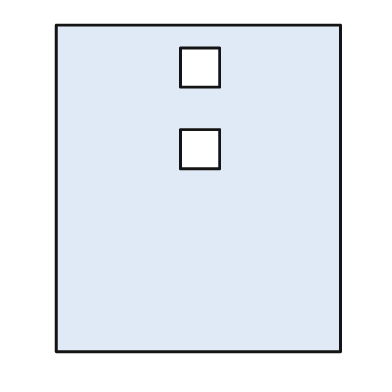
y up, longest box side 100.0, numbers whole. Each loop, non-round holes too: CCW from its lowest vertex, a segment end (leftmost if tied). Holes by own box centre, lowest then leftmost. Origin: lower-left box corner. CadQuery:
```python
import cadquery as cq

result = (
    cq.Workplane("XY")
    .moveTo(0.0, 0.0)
    .lineTo(87.0, 0.0)
    .lineTo(87.0, 100.0)
    .lineTo(0.0, 100.0)
    .close()
    .moveTo(38.0, 56.0)
    .lineTo(50.0, 56.0)
    .lineTo(50.0, 68.0)
    .lineTo(38.0, 68.0)
    .close()
    .moveTo(38.0, 81.0)
    .lineTo(50.0, 81.0)
    .lineTo(50.0, 93.0)
    .lineTo(38.0, 93.0)
    .close()
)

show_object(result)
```